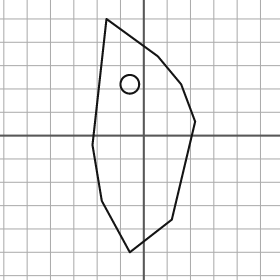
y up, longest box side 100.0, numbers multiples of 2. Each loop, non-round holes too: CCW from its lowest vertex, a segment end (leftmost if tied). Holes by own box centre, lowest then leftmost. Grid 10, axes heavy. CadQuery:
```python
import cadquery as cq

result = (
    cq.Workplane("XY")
    .moveTo(-6.0, -50.0)
    .lineTo(12.0, -36.0)
    .lineTo(22.0, 6.0)
    .lineTo(16.0, 22.0)
    .lineTo(6.0, 34.0)
    .lineTo(-16.0, 50.0)
    .lineTo(-22.0, -4.0)
    .lineTo(-18.0, -28.0)
    .close()
    .moveTo(-6.0, 22.0)
    .circle(4.0)
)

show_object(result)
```